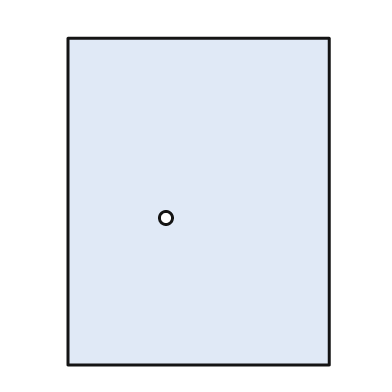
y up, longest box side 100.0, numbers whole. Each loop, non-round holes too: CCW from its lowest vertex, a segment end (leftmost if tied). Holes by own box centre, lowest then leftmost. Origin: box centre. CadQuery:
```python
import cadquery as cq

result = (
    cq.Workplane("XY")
    .moveTo(-40.0, -50.0)
    .lineTo(40.0, -50.0)
    .lineTo(40.0, 50.0)
    .lineTo(-40.0, 50.0)
    .close()
    .moveTo(-10.0, -5.0)
    .circle(2.0)
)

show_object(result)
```